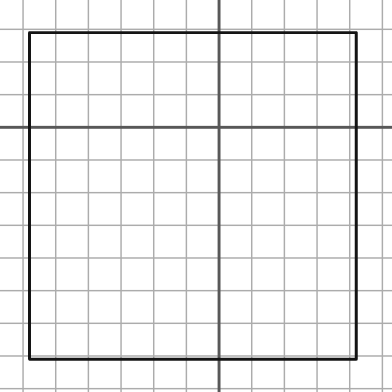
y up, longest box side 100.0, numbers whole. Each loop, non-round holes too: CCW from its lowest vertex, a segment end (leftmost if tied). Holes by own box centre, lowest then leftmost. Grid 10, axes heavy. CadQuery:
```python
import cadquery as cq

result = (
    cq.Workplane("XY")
    .moveTo(-58.0, -71.0)
    .lineTo(42.0, -71.0)
    .lineTo(42.0, 29.0)
    .lineTo(-58.0, 29.0)
    .close()
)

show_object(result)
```